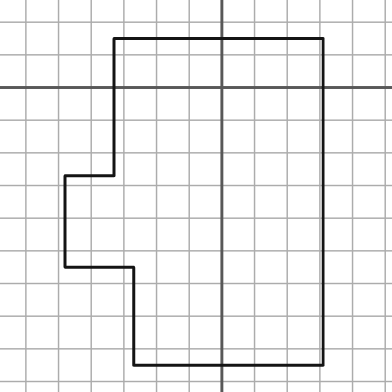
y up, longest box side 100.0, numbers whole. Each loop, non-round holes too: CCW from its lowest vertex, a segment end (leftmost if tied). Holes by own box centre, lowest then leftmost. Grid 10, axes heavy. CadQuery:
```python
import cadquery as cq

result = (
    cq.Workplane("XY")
    .moveTo(-27.0, -85.0)
    .lineTo(31.0, -85.0)
    .lineTo(31.0, 15.0)
    .lineTo(-33.0, 15.0)
    .lineTo(-33.0, -27.0)
    .lineTo(-48.0, -27.0)
    .lineTo(-48.0, -55.0)
    .lineTo(-27.0, -55.0)
    .close()
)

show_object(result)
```